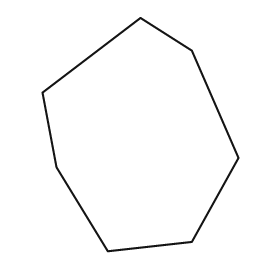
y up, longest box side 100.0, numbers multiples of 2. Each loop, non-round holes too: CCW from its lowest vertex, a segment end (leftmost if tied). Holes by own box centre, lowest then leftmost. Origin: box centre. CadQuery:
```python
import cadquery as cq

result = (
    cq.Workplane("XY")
    .moveTo(-14.0, -50.0)
    .lineTo(22.0, -46.0)
    .lineTo(42.0, -10.0)
    .lineTo(22.0, 36.0)
    .lineTo(0.0, 50.0)
    .lineTo(-42.0, 18.0)
    .lineTo(-36.0, -14.0)
    .close()
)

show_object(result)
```